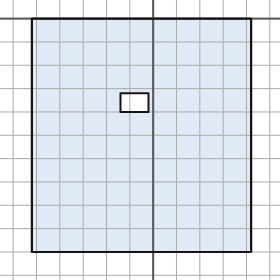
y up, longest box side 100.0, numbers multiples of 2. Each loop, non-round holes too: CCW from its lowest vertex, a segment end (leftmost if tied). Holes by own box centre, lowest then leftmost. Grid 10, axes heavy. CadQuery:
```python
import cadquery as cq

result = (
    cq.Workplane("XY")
    .moveTo(-52.0, -100.0)
    .lineTo(42.0, -100.0)
    .lineTo(42.0, 0.0)
    .lineTo(-52.0, 0.0)
    .close()
    .moveTo(-14.0, -40.0)
    .lineTo(-2.0, -40.0)
    .lineTo(-2.0, -32.0)
    .lineTo(-14.0, -32.0)
    .close()
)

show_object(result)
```